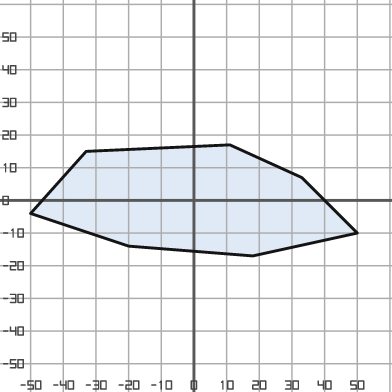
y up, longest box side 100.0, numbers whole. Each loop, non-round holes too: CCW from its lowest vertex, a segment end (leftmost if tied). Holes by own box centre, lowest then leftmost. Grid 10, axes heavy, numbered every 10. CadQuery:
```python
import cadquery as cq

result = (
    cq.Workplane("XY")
    .moveTo(18.0, -17.0)
    .lineTo(50.0, -10.0)
    .lineTo(33.0, 7.0)
    .lineTo(11.0, 17.0)
    .lineTo(-33.0, 15.0)
    .lineTo(-50.0, -4.0)
    .lineTo(-20.0, -14.0)
    .close()
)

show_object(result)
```